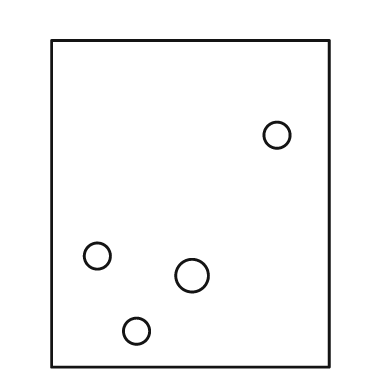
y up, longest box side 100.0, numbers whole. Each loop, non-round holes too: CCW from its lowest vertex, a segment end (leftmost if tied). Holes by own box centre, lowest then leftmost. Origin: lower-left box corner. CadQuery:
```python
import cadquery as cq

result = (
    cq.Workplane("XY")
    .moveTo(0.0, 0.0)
    .lineTo(85.0, 0.0)
    .lineTo(85.0, 100.0)
    .lineTo(0.0, 100.0)
    .close()
    .moveTo(26.0, 11.0)
    .circle(4.0)
    .moveTo(43.0, 28.0)
    .circle(5.0)
    .moveTo(14.0, 34.0)
    .circle(4.0)
    .moveTo(69.0, 71.0)
    .circle(4.0)
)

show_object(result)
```